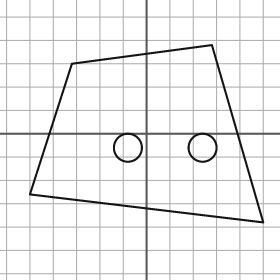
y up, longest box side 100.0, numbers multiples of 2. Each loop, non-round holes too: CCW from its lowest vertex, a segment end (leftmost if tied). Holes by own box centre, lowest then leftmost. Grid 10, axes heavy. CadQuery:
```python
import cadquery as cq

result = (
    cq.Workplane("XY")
    .moveTo(50.0, -38.0)
    .lineTo(28.0, 38.0)
    .lineTo(-32.0, 30.0)
    .lineTo(-50.0, -26.0)
    .close()
    .moveTo(-8.0, -6.0)
    .circle(6.0)
    .moveTo(24.0, -6.0)
    .circle(6.0)
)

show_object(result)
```